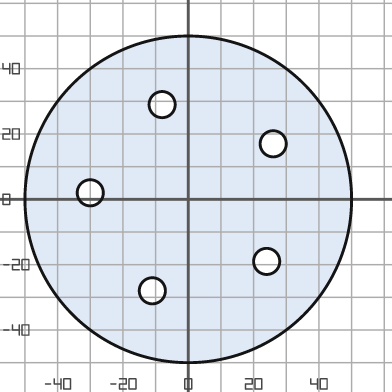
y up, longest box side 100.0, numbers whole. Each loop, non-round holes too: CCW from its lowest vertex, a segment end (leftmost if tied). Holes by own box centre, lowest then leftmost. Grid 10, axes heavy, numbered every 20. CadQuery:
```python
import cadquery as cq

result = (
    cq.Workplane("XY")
    .moveTo(0.0, 0.0)
    .circle(50.0)
    .moveTo(-11.0, -28.0)
    .circle(4.0)
    .moveTo(24.0, -19.0)
    .circle(4.0)
    .moveTo(-30.0, 2.0)
    .circle(4.0)
    .moveTo(26.0, 17.0)
    .circle(4.0)
    .moveTo(-8.0, 29.0)
    .circle(4.0)
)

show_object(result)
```